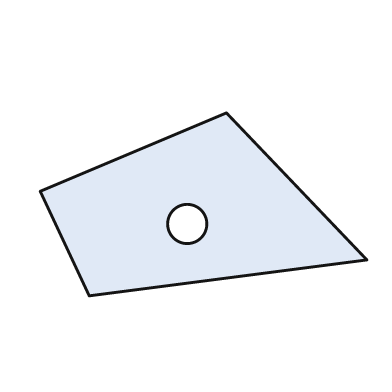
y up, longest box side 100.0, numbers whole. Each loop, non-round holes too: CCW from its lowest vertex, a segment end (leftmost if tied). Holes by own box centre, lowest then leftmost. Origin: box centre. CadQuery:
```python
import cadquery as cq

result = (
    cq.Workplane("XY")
    .moveTo(-35.0, -28.0)
    .lineTo(50.0, -17.0)
    .lineTo(7.0, 28.0)
    .lineTo(-50.0, 4.0)
    .close()
    .moveTo(-5.0, -6.0)
    .circle(6.0)
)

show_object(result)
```